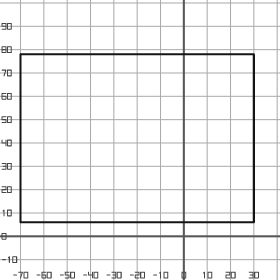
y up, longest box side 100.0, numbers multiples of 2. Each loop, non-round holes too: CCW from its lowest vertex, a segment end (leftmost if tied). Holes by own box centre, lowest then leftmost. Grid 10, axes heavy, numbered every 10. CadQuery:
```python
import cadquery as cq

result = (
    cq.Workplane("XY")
    .moveTo(-70.0, 6.0)
    .lineTo(30.0, 6.0)
    .lineTo(30.0, 78.0)
    .lineTo(-70.0, 78.0)
    .close()
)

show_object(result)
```